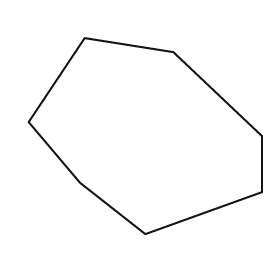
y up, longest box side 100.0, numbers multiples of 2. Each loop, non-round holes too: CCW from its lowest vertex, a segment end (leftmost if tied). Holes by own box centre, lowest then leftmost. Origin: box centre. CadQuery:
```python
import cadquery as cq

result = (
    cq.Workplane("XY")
    .moveTo(0.0, -42.0)
    .lineTo(50.0, -24.0)
    .lineTo(50.0, 0.0)
    .lineTo(12.0, 36.0)
    .lineTo(-26.0, 42.0)
    .lineTo(-50.0, 6.0)
    .lineTo(-28.0, -20.0)
    .close()
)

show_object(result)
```